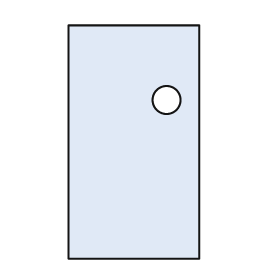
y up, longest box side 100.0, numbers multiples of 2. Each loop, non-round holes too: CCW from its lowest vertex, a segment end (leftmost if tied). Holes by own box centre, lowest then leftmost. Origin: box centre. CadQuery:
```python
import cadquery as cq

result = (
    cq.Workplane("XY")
    .moveTo(-28.0, -50.0)
    .lineTo(28.0, -50.0)
    .lineTo(28.0, 50.0)
    .lineTo(-28.0, 50.0)
    .close()
    .moveTo(14.0, 18.0)
    .circle(6.0)
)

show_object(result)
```